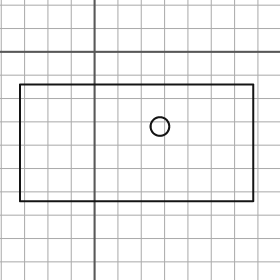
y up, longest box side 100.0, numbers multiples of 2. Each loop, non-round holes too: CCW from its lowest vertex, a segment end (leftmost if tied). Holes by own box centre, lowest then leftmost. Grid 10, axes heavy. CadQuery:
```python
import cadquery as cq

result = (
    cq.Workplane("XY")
    .moveTo(-32.0, -64.0)
    .lineTo(68.0, -64.0)
    .lineTo(68.0, -14.0)
    .lineTo(-32.0, -14.0)
    .close()
    .moveTo(28.0, -32.0)
    .circle(4.0)
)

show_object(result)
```